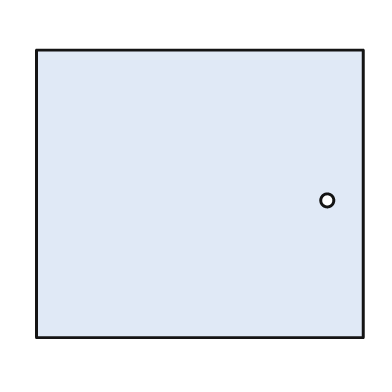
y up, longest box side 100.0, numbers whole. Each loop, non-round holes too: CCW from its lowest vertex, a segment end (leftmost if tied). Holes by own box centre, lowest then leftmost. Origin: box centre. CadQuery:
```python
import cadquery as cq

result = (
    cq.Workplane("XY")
    .moveTo(-50.0, -44.0)
    .lineTo(50.0, -44.0)
    .lineTo(50.0, 44.0)
    .lineTo(-50.0, 44.0)
    .close()
    .moveTo(39.0, -2.0)
    .circle(2.0)
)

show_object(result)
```